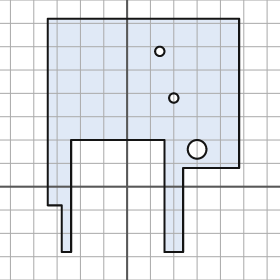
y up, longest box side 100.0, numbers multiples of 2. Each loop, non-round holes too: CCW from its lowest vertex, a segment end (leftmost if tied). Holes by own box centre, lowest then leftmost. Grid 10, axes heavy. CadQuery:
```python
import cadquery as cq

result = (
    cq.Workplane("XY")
    .moveTo(-28.0, -28.0)
    .lineTo(-24.0, -28.0)
    .lineTo(-24.0, 20.0)
    .lineTo(16.0, 20.0)
    .lineTo(16.0, -28.0)
    .lineTo(24.0, -28.0)
    .lineTo(24.0, 8.0)
    .lineTo(48.0, 8.0)
    .lineTo(48.0, 72.0)
    .lineTo(-34.0, 72.0)
    .lineTo(-34.0, -8.0)
    .lineTo(-28.0, -8.0)
    .close()
    .moveTo(30.0, 16.0)
    .circle(4.0)
    .moveTo(20.0, 38.0)
    .circle(2.0)
    .moveTo(14.0, 58.0)
    .circle(2.0)
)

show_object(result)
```